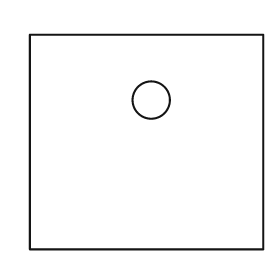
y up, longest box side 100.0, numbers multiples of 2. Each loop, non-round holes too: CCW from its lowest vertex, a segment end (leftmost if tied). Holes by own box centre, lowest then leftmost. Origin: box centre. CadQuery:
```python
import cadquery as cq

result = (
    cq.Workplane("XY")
    .moveTo(-50.0, -46.0)
    .lineTo(50.0, -46.0)
    .lineTo(50.0, 46.0)
    .lineTo(-50.0, 46.0)
    .close()
    .moveTo(2.0, 18.0)
    .circle(8.0)
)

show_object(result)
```